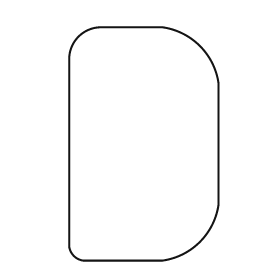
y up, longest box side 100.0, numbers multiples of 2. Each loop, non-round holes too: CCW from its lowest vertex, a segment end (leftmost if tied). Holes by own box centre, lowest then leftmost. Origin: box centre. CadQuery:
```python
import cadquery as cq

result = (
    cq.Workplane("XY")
    .moveTo(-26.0, -50.0)
    .lineTo(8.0, -50.0)
    .threePointArc((24.0, -42.0), (32.0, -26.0))
    .lineTo(32.0, 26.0)
    .threePointArc((24.0, 42.0), (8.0, 50.0))
    .lineTo(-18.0, 50.0)
    .threePointArc((-28.0, 46.0), (-32.0, 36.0))
    .lineTo(-32.0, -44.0)
    .threePointArc((-30.0, -48.0), (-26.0, -50.0))
    .close()
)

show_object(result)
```